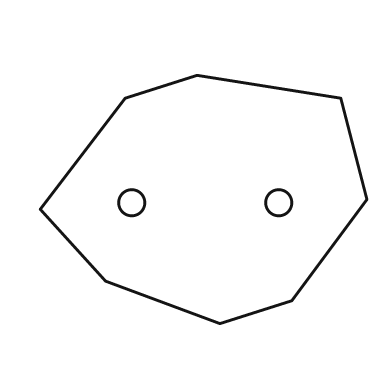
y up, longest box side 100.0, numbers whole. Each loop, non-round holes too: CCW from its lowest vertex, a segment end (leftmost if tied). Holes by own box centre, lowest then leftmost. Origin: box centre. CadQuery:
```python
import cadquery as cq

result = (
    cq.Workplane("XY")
    .moveTo(5.0, -38.0)
    .lineTo(27.0, -31.0)
    .lineTo(50.0, 0.0)
    .lineTo(42.0, 31.0)
    .lineTo(-2.0, 38.0)
    .lineTo(-24.0, 31.0)
    .lineTo(-50.0, -3.0)
    .lineTo(-30.0, -25.0)
    .close()
    .moveTo(-22.0, -1.0)
    .circle(4.0)
    .moveTo(23.0, -1.0)
    .circle(4.0)
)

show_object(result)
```